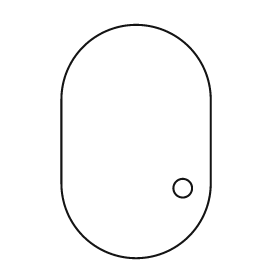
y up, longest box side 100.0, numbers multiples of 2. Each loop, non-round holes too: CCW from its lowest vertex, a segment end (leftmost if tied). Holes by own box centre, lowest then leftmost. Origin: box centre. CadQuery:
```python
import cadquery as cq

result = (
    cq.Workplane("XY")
    .moveTo(-32.0, -18.0)
    .threePointArc((0.0, -50.0), (32.0, -18.0))
    .lineTo(32.0, 18.0)
    .threePointArc((0.0, 50.0), (-32.0, 18.0))
    .close()
    .moveTo(20.0, -20.0)
    .circle(4.0)
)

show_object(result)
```